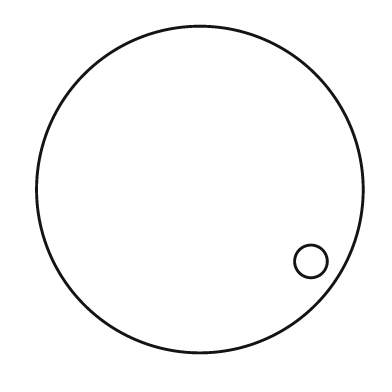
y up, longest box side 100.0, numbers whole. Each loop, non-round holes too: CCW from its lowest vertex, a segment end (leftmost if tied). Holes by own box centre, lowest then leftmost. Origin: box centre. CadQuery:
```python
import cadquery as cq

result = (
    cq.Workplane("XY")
    .moveTo(0.0, 0.0)
    .circle(50.0)
    .moveTo(34.0, -22.0)
    .circle(5.0)
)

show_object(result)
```